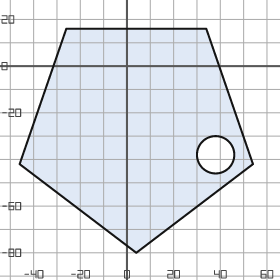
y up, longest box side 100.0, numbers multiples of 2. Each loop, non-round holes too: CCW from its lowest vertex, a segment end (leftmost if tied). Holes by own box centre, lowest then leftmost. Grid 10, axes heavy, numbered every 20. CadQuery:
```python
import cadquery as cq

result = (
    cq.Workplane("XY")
    .moveTo(4.0, -80.0)
    .lineTo(54.0, -42.0)
    .lineTo(34.0, 16.0)
    .lineTo(-26.0, 16.0)
    .lineTo(-46.0, -42.0)
    .close()
    .moveTo(38.0, -38.0)
    .circle(8.0)
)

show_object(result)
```